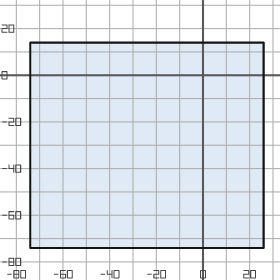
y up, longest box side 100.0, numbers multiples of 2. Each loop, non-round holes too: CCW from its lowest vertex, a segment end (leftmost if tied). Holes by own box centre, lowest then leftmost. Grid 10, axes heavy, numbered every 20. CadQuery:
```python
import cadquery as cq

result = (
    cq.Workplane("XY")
    .moveTo(-74.0, -74.0)
    .lineTo(26.0, -74.0)
    .lineTo(26.0, 14.0)
    .lineTo(-74.0, 14.0)
    .close()
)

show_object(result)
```